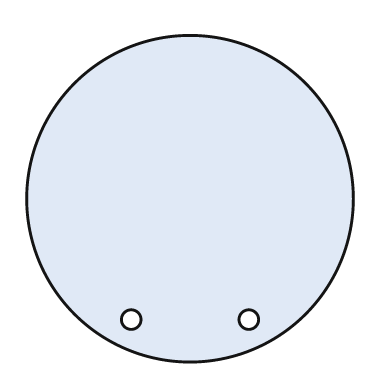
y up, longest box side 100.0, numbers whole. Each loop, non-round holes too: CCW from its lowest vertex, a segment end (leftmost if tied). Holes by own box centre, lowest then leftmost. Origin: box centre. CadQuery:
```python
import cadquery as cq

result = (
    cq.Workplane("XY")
    .moveTo(0.0, 0.0)
    .circle(50.0)
    .moveTo(-18.0, -37.0)
    .circle(3.0)
    .moveTo(18.0, -37.0)
    .circle(3.0)
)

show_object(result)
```